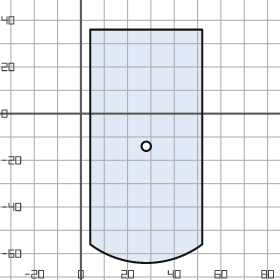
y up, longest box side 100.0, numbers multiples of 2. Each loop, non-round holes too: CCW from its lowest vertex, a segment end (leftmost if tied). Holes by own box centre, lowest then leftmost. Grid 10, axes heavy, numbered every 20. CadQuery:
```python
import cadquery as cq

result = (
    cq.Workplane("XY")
    .moveTo(4.0, -56.0)
    .threePointArc((28.0, -64.0), (52.0, -56.0))
    .lineTo(52.0, 36.0)
    .lineTo(4.0, 36.0)
    .close()
    .moveTo(28.0, -14.0)
    .circle(2.0)
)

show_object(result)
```